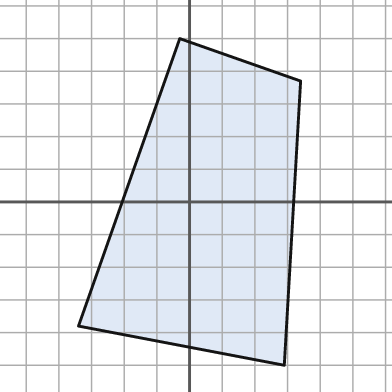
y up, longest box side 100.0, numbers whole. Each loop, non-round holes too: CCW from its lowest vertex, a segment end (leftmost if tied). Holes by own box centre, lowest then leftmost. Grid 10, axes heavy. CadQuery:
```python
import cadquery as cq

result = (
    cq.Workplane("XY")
    .moveTo(29.0, -50.0)
    .lineTo(34.0, 37.0)
    .lineTo(-3.0, 50.0)
    .lineTo(-34.0, -38.0)
    .close()
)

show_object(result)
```